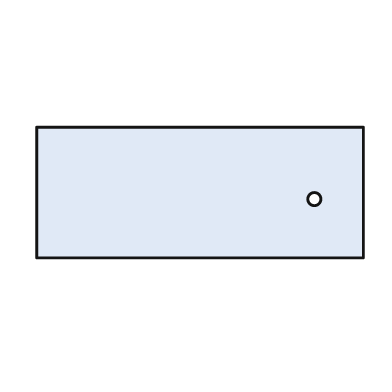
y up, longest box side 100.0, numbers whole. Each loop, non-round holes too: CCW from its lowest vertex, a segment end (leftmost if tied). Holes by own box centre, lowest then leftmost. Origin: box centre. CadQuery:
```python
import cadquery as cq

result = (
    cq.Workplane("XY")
    .moveTo(-50.0, -20.0)
    .lineTo(50.0, -20.0)
    .lineTo(50.0, 20.0)
    .lineTo(-50.0, 20.0)
    .close()
    .moveTo(35.0, -2.0)
    .circle(2.0)
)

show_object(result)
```